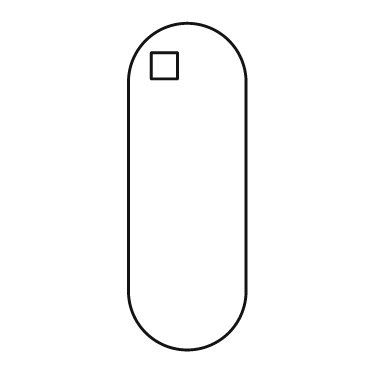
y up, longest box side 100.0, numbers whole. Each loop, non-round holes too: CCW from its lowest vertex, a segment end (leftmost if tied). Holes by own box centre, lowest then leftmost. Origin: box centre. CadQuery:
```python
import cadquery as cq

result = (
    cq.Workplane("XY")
    .moveTo(-18.0, -32.0)
    .threePointArc((0.0, -50.0), (18.0, -32.0))
    .lineTo(18.0, 32.0)
    .threePointArc((0.0, 50.0), (-18.0, 32.0))
    .close()
    .moveTo(-11.0, 33.0)
    .lineTo(-3.0, 33.0)
    .lineTo(-3.0, 41.0)
    .lineTo(-11.0, 41.0)
    .close()
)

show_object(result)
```